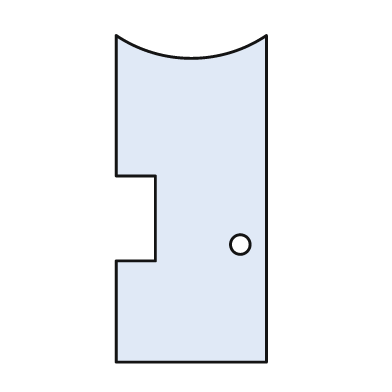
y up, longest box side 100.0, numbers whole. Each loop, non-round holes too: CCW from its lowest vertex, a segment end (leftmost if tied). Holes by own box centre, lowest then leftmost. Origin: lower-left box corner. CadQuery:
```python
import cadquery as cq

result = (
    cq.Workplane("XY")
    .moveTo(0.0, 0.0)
    .lineTo(46.0, 0.0)
    .lineTo(46.0, 100.0)
    .threePointArc((23.0, 93.0), (0.0, 100.0))
    .lineTo(0.0, 57.0)
    .lineTo(12.0, 57.0)
    .lineTo(12.0, 31.0)
    .lineTo(0.0, 31.0)
    .close()
    .moveTo(38.0, 36.0)
    .circle(3.0)
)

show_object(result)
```